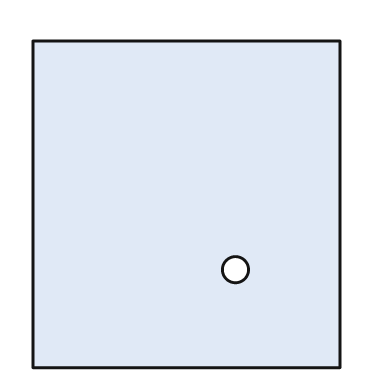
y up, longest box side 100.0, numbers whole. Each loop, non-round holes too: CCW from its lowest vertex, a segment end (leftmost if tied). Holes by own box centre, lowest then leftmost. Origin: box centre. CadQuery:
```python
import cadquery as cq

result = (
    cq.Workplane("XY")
    .moveTo(-47.0, -50.0)
    .lineTo(47.0, -50.0)
    .lineTo(47.0, 50.0)
    .lineTo(-47.0, 50.0)
    .close()
    .moveTo(15.0, -20.0)
    .circle(4.0)
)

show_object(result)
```